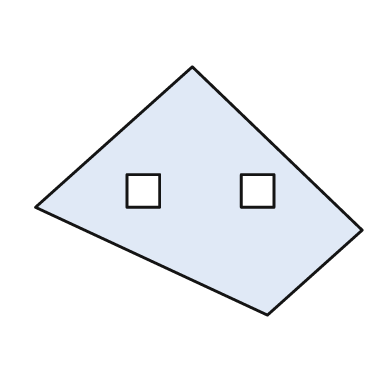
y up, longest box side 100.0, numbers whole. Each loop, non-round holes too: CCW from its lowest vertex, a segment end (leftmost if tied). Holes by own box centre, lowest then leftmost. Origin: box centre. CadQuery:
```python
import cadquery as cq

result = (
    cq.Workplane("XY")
    .moveTo(21.0, -38.0)
    .lineTo(50.0, -12.0)
    .lineTo(-2.0, 38.0)
    .lineTo(-50.0, -5.0)
    .close()
    .moveTo(-22.0, -5.0)
    .lineTo(-12.0, -5.0)
    .lineTo(-12.0, 5.0)
    .lineTo(-22.0, 5.0)
    .close()
    .moveTo(13.0, -5.0)
    .lineTo(23.0, -5.0)
    .lineTo(23.0, 5.0)
    .lineTo(13.0, 5.0)
    .close()
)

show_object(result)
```